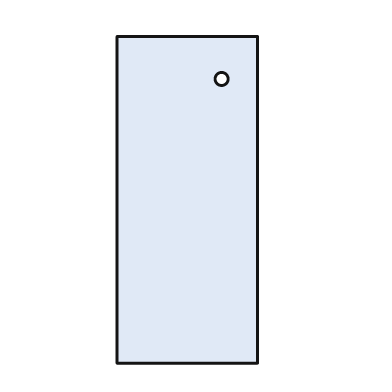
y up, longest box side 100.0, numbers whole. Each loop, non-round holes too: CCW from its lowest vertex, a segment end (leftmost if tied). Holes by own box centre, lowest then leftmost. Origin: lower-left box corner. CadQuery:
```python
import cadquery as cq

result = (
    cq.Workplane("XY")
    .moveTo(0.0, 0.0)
    .lineTo(43.0, 0.0)
    .lineTo(43.0, 100.0)
    .lineTo(0.0, 100.0)
    .close()
    .moveTo(32.0, 87.0)
    .circle(2.0)
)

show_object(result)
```